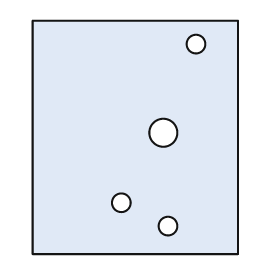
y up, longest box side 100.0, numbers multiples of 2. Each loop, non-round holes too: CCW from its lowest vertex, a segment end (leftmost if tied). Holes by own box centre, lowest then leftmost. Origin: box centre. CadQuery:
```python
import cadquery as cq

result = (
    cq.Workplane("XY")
    .moveTo(-44.0, -50.0)
    .lineTo(44.0, -50.0)
    .lineTo(44.0, 50.0)
    .lineTo(-44.0, 50.0)
    .close()
    .moveTo(14.0, -38.0)
    .circle(4.0)
    .moveTo(-6.0, -28.0)
    .circle(4.0)
    .moveTo(12.0, 2.0)
    .circle(6.0)
    .moveTo(26.0, 40.0)
    .circle(4.0)
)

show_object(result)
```